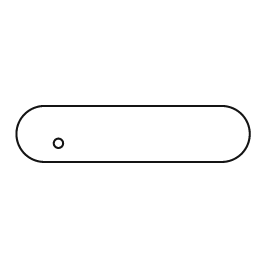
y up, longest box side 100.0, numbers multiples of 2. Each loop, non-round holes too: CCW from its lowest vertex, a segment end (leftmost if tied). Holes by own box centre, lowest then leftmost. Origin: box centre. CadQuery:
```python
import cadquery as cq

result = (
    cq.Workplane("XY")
    .moveTo(-38.0, -12.0)
    .lineTo(38.0, -12.0)
    .threePointArc((50.0, 0.0), (38.0, 12.0))
    .lineTo(-38.0, 12.0)
    .threePointArc((-50.0, 0.0), (-38.0, -12.0))
    .close()
    .moveTo(-32.0, -4.0)
    .circle(2.0)
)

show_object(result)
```